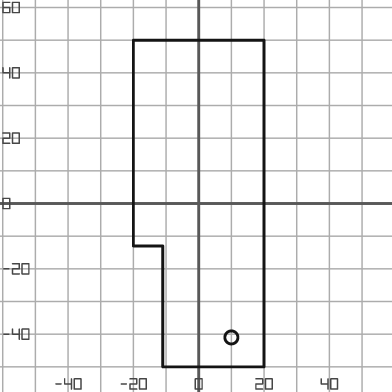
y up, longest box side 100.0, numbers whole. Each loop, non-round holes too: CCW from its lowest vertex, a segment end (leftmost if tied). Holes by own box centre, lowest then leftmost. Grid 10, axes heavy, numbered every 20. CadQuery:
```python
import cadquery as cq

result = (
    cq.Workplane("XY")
    .moveTo(-11.0, -50.0)
    .lineTo(20.0, -50.0)
    .lineTo(20.0, 50.0)
    .lineTo(-20.0, 50.0)
    .lineTo(-20.0, -13.0)
    .lineTo(-11.0, -13.0)
    .close()
    .moveTo(10.0, -41.0)
    .circle(2.0)
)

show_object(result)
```